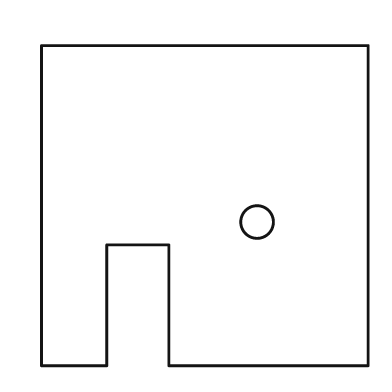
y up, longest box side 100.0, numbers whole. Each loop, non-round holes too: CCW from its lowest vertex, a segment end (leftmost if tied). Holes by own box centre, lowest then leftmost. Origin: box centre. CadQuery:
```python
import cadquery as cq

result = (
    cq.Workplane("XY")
    .moveTo(-50.0, -49.0)
    .lineTo(-30.0, -49.0)
    .lineTo(-30.0, -12.0)
    .lineTo(-11.0, -12.0)
    .lineTo(-11.0, -49.0)
    .lineTo(50.0, -49.0)
    .lineTo(50.0, 49.0)
    .lineTo(-50.0, 49.0)
    .close()
    .moveTo(16.0, -5.0)
    .circle(5.0)
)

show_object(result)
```